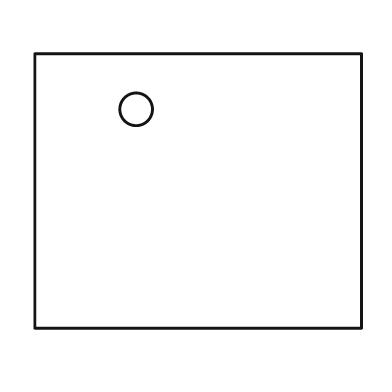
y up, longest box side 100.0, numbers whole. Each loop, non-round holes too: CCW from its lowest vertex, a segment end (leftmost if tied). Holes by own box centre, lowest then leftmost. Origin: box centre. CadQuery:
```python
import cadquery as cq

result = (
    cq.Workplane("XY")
    .moveTo(-50.0, -42.0)
    .lineTo(50.0, -42.0)
    .lineTo(50.0, 42.0)
    .lineTo(-50.0, 42.0)
    .close()
    .moveTo(-19.0, 25.0)
    .circle(5.0)
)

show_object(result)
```